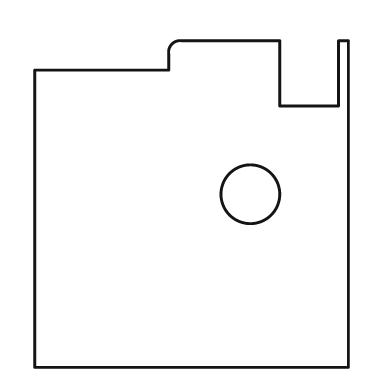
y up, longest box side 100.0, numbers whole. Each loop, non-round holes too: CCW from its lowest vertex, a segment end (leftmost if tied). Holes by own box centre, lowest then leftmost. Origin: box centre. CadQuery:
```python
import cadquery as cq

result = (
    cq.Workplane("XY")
    .moveTo(-48.0, -50.0)
    .lineTo(48.0, -50.0)
    .lineTo(48.0, 50.0)
    .lineTo(45.0, 50.0)
    .lineTo(45.0, 30.0)
    .lineTo(27.0, 30.0)
    .lineTo(27.0, 50.0)
    .lineTo(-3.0, 50.0)
    .threePointArc((-6.0, 49.0), (-7.0, 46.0))
    .lineTo(-7.0, 41.0)
    .lineTo(-48.0, 41.0)
    .close()
    .moveTo(18.0, 3.0)
    .circle(9.0)
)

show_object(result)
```